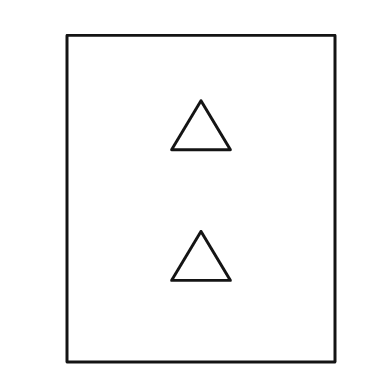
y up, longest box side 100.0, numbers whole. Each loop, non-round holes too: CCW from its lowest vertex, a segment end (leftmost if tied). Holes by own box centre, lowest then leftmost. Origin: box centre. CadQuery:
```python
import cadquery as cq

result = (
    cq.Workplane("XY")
    .moveTo(-41.0, -50.0)
    .lineTo(41.0, -50.0)
    .lineTo(41.0, 50.0)
    .lineTo(-41.0, 50.0)
    .close()
    .moveTo(-9.0, -25.0)
    .lineTo(9.0, -25.0)
    .lineTo(0.0, -10.0)
    .close()
    .moveTo(-9.0, 15.0)
    .lineTo(9.0, 15.0)
    .lineTo(0.0, 30.0)
    .close()
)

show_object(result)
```